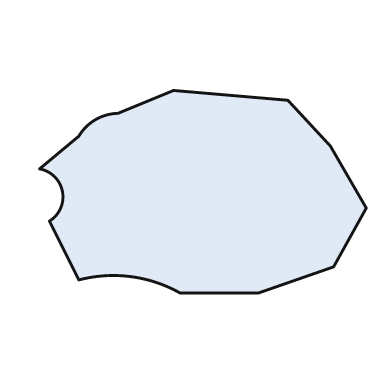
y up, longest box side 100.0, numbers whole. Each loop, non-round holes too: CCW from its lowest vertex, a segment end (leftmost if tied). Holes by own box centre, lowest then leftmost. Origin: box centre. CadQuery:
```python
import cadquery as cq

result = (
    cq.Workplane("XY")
    .moveTo(-7.0, -31.0)
    .lineTo(17.0, -31.0)
    .lineTo(40.0, -23.0)
    .lineTo(50.0, -5.0)
    .lineTo(39.0, 14.0)
    .lineTo(26.0, 28.0)
    .lineTo(-9.0, 31.0)
    .lineTo(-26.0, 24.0)
    .threePointArc((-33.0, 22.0), (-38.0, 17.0))
    .lineTo(-50.0, 7.0)
    .threePointArc((-43.0, 0.0), (-47.0, -9.0))
    .lineTo(-38.0, -27.0)
    .threePointArc((-22.0, -26.0), (-7.0, -31.0))
    .close()
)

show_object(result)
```